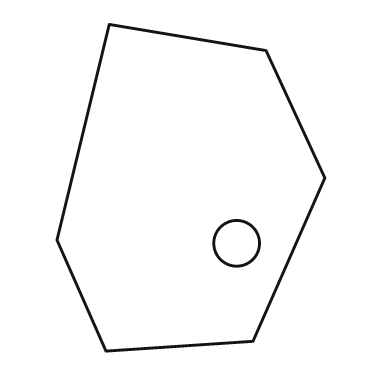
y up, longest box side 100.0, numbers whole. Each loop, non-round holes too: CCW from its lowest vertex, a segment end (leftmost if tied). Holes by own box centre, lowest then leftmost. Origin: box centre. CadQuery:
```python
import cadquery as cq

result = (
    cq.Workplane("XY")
    .moveTo(-26.0, -50.0)
    .lineTo(19.0, -47.0)
    .lineTo(41.0, 3.0)
    .lineTo(23.0, 42.0)
    .lineTo(-25.0, 50.0)
    .lineTo(-41.0, -16.0)
    .close()
    .moveTo(14.0, -17.0)
    .circle(7.0)
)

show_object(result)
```